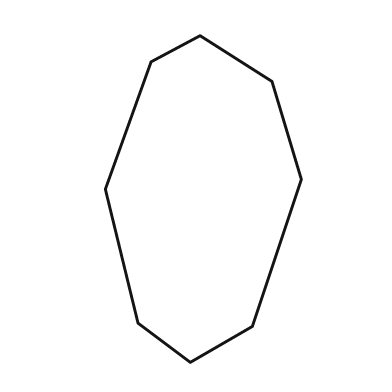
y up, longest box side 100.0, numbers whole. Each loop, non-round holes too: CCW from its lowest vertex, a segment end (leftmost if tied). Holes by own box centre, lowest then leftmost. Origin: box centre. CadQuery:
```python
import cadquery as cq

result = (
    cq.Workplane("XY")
    .moveTo(-4.0, -50.0)
    .lineTo(15.0, -39.0)
    .lineTo(30.0, 6.0)
    .lineTo(21.0, 36.0)
    .lineTo(-1.0, 50.0)
    .lineTo(-16.0, 42.0)
    .lineTo(-30.0, 3.0)
    .lineTo(-20.0, -38.0)
    .close()
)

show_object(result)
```